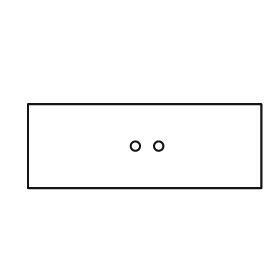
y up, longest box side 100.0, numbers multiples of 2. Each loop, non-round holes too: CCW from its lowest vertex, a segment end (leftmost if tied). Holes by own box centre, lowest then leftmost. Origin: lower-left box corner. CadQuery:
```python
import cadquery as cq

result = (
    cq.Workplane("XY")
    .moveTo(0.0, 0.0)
    .lineTo(100.0, 0.0)
    .lineTo(100.0, 36.0)
    .lineTo(0.0, 36.0)
    .close()
    .moveTo(46.0, 18.0)
    .circle(2.0)
    .moveTo(56.0, 18.0)
    .circle(2.0)
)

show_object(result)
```